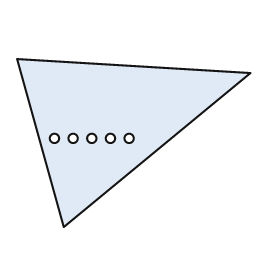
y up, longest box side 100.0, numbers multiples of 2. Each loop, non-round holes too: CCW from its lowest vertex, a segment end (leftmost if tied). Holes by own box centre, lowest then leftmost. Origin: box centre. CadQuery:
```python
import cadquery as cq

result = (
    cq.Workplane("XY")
    .moveTo(-30.0, -36.0)
    .lineTo(50.0, 30.0)
    .lineTo(-50.0, 36.0)
    .close()
    .moveTo(-34.0, 2.0)
    .circle(2.0)
    .moveTo(-26.0, 2.0)
    .circle(2.0)
    .moveTo(-18.0, 2.0)
    .circle(2.0)
    .moveTo(-10.0, 2.0)
    .circle(2.0)
    .moveTo(-2.0, 2.0)
    .circle(2.0)
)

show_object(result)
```